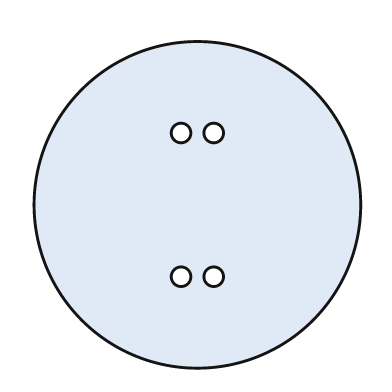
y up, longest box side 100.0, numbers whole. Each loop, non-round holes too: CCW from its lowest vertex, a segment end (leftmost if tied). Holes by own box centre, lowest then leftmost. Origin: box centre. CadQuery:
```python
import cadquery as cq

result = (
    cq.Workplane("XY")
    .moveTo(0.0, 0.0)
    .circle(50.0)
    .moveTo(-5.0, -22.0)
    .circle(3.0)
    .moveTo(5.0, -22.0)
    .circle(3.0)
    .moveTo(-5.0, 22.0)
    .circle(3.0)
    .moveTo(5.0, 22.0)
    .circle(3.0)
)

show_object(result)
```